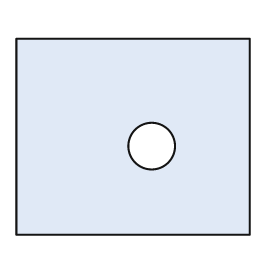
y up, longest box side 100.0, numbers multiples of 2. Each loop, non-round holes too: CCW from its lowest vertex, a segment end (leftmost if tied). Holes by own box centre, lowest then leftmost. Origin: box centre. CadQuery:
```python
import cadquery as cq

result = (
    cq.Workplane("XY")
    .moveTo(-50.0, -42.0)
    .lineTo(50.0, -42.0)
    .lineTo(50.0, 42.0)
    .lineTo(-50.0, 42.0)
    .close()
    .moveTo(8.0, -4.0)
    .circle(10.0)
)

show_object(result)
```